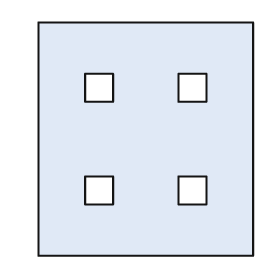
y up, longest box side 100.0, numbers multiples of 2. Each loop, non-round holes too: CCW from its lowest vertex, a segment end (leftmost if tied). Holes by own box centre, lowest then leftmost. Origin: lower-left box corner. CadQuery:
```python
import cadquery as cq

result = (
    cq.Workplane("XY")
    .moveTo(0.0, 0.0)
    .lineTo(92.0, 0.0)
    .lineTo(92.0, 100.0)
    .lineTo(0.0, 100.0)
    .close()
    .moveTo(20.0, 22.0)
    .lineTo(32.0, 22.0)
    .lineTo(32.0, 34.0)
    .lineTo(20.0, 34.0)
    .close()
    .moveTo(60.0, 22.0)
    .lineTo(72.0, 22.0)
    .lineTo(72.0, 34.0)
    .lineTo(60.0, 34.0)
    .close()
    .moveTo(20.0, 66.0)
    .lineTo(32.0, 66.0)
    .lineTo(32.0, 78.0)
    .lineTo(20.0, 78.0)
    .close()
    .moveTo(60.0, 66.0)
    .lineTo(72.0, 66.0)
    .lineTo(72.0, 78.0)
    .lineTo(60.0, 78.0)
    .close()
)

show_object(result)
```